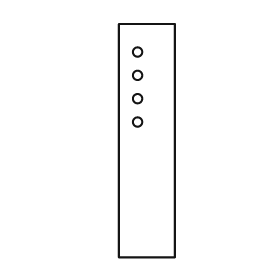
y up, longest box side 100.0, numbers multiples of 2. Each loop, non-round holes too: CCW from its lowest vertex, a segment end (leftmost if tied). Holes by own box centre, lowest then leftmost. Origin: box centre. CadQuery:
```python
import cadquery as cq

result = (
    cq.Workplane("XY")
    .moveTo(-12.0, -50.0)
    .lineTo(12.0, -50.0)
    .lineTo(12.0, 50.0)
    .lineTo(-12.0, 50.0)
    .close()
    .moveTo(-4.0, 8.0)
    .circle(2.0)
    .moveTo(-4.0, 18.0)
    .circle(2.0)
    .moveTo(-4.0, 28.0)
    .circle(2.0)
    .moveTo(-4.0, 38.0)
    .circle(2.0)
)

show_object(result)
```